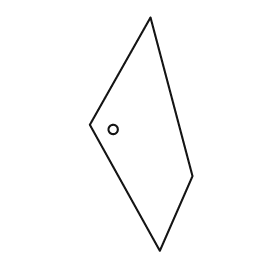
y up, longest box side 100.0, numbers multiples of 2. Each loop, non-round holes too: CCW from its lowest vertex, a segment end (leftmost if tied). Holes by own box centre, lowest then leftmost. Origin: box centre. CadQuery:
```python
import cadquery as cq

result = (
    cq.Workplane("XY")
    .moveTo(8.0, -50.0)
    .lineTo(22.0, -18.0)
    .lineTo(4.0, 50.0)
    .lineTo(-22.0, 4.0)
    .close()
    .moveTo(-12.0, 2.0)
    .circle(2.0)
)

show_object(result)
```